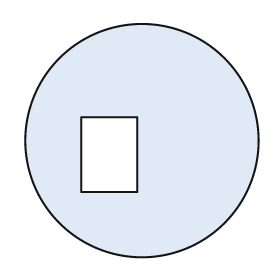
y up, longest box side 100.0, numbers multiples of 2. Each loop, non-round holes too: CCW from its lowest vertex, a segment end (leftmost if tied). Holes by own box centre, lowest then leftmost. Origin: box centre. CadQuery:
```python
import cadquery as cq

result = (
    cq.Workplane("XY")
    .moveTo(0.0, 0.0)
    .circle(50.0)
    .moveTo(-26.0, -22.0)
    .lineTo(-2.0, -22.0)
    .lineTo(-2.0, 10.0)
    .lineTo(-26.0, 10.0)
    .close()
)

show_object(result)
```